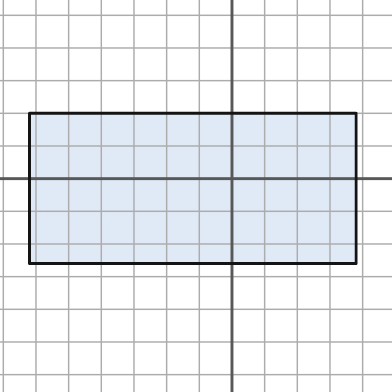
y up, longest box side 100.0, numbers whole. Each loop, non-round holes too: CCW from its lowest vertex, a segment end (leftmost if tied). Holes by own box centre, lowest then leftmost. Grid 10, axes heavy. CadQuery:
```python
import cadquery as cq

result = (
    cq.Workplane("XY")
    .moveTo(-62.0, -26.0)
    .lineTo(38.0, -26.0)
    .lineTo(38.0, 20.0)
    .lineTo(-62.0, 20.0)
    .close()
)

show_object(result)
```